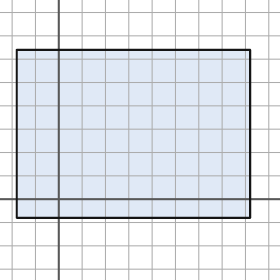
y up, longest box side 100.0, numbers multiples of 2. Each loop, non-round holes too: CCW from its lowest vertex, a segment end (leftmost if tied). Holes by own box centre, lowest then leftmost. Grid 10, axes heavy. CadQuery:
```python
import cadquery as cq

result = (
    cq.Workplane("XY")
    .moveTo(-18.0, -8.0)
    .lineTo(82.0, -8.0)
    .lineTo(82.0, 64.0)
    .lineTo(-18.0, 64.0)
    .close()
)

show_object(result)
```